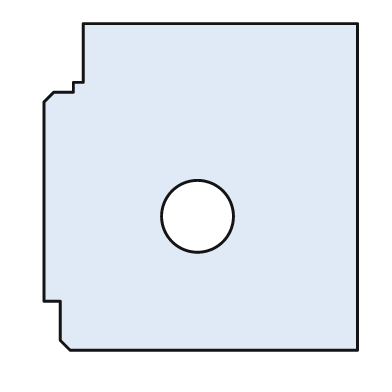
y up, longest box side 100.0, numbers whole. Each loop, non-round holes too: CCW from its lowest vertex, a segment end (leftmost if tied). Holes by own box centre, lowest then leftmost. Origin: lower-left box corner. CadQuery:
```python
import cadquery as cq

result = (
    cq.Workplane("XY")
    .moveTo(8.0, 0.0)
    .lineTo(96.0, 0.0)
    .lineTo(96.0, 100.0)
    .lineTo(12.0, 100.0)
    .lineTo(12.0, 82.0)
    .lineTo(9.0, 82.0)
    .lineTo(9.0, 79.0)
    .lineTo(3.0, 79.0)
    .lineTo(0.0, 76.0)
    .lineTo(0.0, 15.0)
    .lineTo(5.0, 15.0)
    .lineTo(5.0, 3.0)
    .close()
    .moveTo(47.0, 41.0)
    .circle(11.0)
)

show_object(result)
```